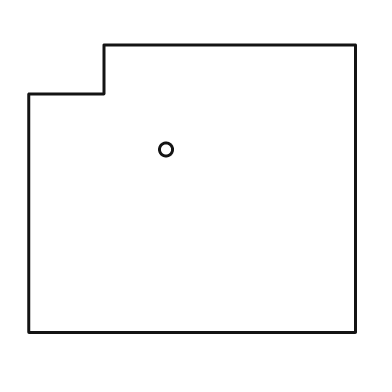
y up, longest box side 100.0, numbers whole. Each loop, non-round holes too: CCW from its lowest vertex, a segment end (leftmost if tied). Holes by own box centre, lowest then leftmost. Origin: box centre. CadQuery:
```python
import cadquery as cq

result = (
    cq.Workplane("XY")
    .moveTo(-50.0, -44.0)
    .lineTo(50.0, -44.0)
    .lineTo(50.0, 44.0)
    .lineTo(-27.0, 44.0)
    .lineTo(-27.0, 29.0)
    .lineTo(-50.0, 29.0)
    .close()
    .moveTo(-8.0, 12.0)
    .circle(2.0)
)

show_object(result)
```